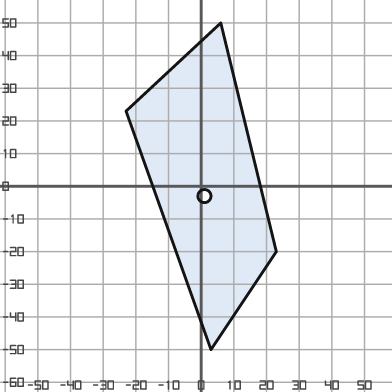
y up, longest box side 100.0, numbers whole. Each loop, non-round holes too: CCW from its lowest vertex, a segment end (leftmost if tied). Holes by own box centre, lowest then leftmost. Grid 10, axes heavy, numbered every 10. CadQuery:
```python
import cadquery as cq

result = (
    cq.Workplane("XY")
    .moveTo(3.0, -50.0)
    .lineTo(23.0, -20.0)
    .lineTo(6.0, 50.0)
    .lineTo(-23.0, 23.0)
    .close()
    .moveTo(1.0, -3.0)
    .circle(2.0)
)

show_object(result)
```